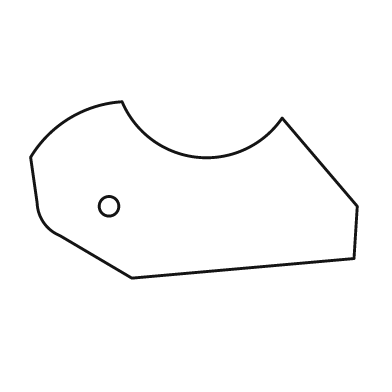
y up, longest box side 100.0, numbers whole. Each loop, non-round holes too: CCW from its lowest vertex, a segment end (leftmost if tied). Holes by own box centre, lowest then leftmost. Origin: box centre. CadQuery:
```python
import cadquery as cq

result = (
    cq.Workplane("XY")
    .moveTo(-19.0, -27.0)
    .lineTo(49.0, -21.0)
    .lineTo(50.0, -5.0)
    .lineTo(27.0, 22.0)
    .threePointArc((1.0, 10.0), (-22.0, 27.0))
    .threePointArc((-38.0, 22.0), (-50.0, 10.0))
    .lineTo(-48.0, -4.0)
    .threePointArc((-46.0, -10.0), (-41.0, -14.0))
    .close()
    .moveTo(-26.0, -5.0)
    .circle(3.0)
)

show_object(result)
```